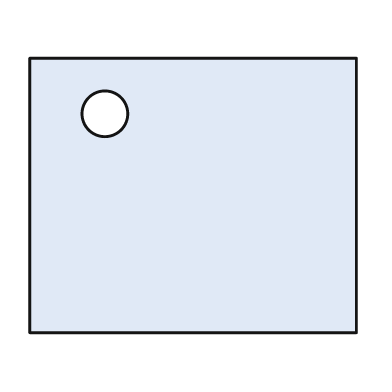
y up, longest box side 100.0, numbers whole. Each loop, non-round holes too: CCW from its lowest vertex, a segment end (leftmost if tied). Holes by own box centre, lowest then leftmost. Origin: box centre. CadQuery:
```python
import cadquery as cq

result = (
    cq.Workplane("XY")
    .moveTo(-50.0, -42.0)
    .lineTo(50.0, -42.0)
    .lineTo(50.0, 42.0)
    .lineTo(-50.0, 42.0)
    .close()
    .moveTo(-27.0, 25.0)
    .circle(7.0)
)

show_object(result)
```